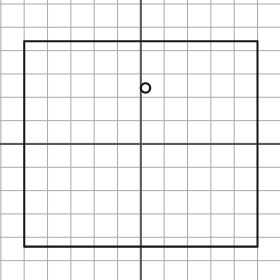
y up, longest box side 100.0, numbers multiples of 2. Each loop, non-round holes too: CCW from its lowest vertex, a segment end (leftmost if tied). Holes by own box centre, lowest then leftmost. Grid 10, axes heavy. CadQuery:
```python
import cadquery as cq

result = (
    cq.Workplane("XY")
    .moveTo(-50.0, -44.0)
    .lineTo(50.0, -44.0)
    .lineTo(50.0, 44.0)
    .lineTo(-50.0, 44.0)
    .close()
    .moveTo(2.0, 24.0)
    .circle(2.0)
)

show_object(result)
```